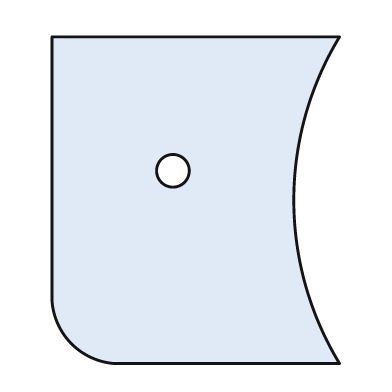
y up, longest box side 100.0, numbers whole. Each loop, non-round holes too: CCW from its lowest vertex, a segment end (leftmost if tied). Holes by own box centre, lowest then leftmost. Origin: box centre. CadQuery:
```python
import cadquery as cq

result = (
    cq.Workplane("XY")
    .moveTo(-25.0, -50.0)
    .lineTo(44.0, -50.0)
    .threePointArc((30.0, 0.0), (44.0, 50.0))
    .lineTo(-44.0, 50.0)
    .lineTo(-44.0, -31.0)
    .threePointArc((-38.0, -44.0), (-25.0, -50.0))
    .close()
    .moveTo(-7.0, 9.0)
    .circle(5.0)
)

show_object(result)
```